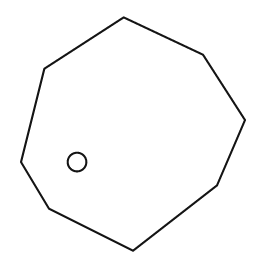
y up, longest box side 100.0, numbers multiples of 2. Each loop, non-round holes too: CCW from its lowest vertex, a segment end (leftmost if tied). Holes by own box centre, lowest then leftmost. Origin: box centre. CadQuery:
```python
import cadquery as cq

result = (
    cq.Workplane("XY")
    .moveTo(0.0, -50.0)
    .lineTo(36.0, -22.0)
    .lineTo(48.0, 6.0)
    .lineTo(30.0, 34.0)
    .lineTo(-4.0, 50.0)
    .lineTo(-38.0, 28.0)
    .lineTo(-48.0, -12.0)
    .lineTo(-36.0, -32.0)
    .close()
    .moveTo(-24.0, -12.0)
    .circle(4.0)
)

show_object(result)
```